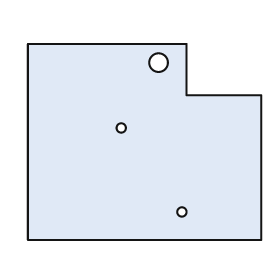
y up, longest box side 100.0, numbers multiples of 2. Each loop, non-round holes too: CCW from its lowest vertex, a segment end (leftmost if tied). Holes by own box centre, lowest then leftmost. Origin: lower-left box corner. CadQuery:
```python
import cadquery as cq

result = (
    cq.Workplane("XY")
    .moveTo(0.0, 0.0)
    .lineTo(100.0, 0.0)
    .lineTo(100.0, 62.0)
    .lineTo(68.0, 62.0)
    .lineTo(68.0, 84.0)
    .lineTo(0.0, 84.0)
    .close()
    .moveTo(66.0, 12.0)
    .circle(2.0)
    .moveTo(40.0, 48.0)
    .circle(2.0)
    .moveTo(56.0, 76.0)
    .circle(4.0)
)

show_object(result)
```